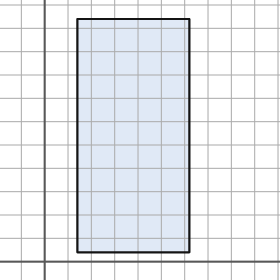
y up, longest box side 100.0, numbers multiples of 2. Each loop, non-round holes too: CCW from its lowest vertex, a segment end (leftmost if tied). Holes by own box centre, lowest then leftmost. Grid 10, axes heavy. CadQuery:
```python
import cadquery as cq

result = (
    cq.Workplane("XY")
    .moveTo(14.0, 4.0)
    .lineTo(62.0, 4.0)
    .lineTo(62.0, 104.0)
    .lineTo(14.0, 104.0)
    .close()
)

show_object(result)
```